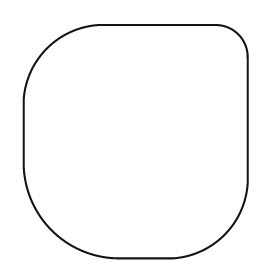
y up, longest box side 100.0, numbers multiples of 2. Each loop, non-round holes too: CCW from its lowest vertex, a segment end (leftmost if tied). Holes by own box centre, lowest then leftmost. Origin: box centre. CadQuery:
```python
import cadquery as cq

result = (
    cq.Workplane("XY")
    .moveTo(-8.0, -50.0)
    .lineTo(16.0, -50.0)
    .threePointArc((38.0, -40.0), (48.0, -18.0))
    .lineTo(48.0, 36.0)
    .threePointArc((44.0, 46.0), (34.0, 50.0))
    .lineTo(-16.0, 50.0)
    .threePointArc((-38.0, 40.0), (-48.0, 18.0))
    .lineTo(-48.0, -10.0)
    .threePointArc((-36.0, -38.0), (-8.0, -50.0))
    .close()
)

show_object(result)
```